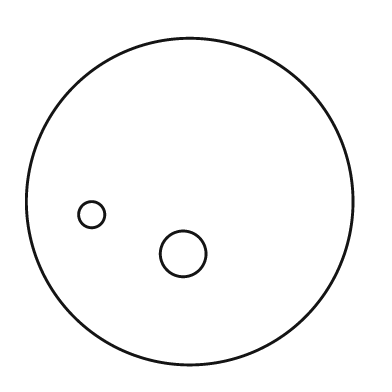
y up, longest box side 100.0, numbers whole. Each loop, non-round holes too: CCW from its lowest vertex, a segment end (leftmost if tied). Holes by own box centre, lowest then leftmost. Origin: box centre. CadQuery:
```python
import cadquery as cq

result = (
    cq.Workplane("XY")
    .moveTo(0.0, 0.0)
    .circle(50.0)
    .moveTo(-2.0, -16.0)
    .circle(7.0)
    .moveTo(-30.0, -4.0)
    .circle(4.0)
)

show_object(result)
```